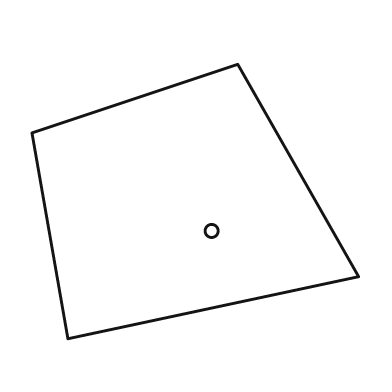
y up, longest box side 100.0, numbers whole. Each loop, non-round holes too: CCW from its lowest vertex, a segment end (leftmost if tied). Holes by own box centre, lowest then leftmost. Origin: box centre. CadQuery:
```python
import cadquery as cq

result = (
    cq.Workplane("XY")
    .moveTo(-39.0, -42.0)
    .lineTo(50.0, -23.0)
    .lineTo(13.0, 42.0)
    .lineTo(-50.0, 21.0)
    .close()
    .moveTo(5.0, -9.0)
    .circle(2.0)
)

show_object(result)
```